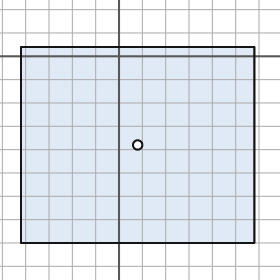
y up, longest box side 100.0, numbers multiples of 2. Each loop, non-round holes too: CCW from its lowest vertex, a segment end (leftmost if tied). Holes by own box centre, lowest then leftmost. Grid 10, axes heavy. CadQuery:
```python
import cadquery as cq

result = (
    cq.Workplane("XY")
    .moveTo(-42.0, -80.0)
    .lineTo(58.0, -80.0)
    .lineTo(58.0, 4.0)
    .lineTo(-42.0, 4.0)
    .close()
    .moveTo(8.0, -38.0)
    .circle(2.0)
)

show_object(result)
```